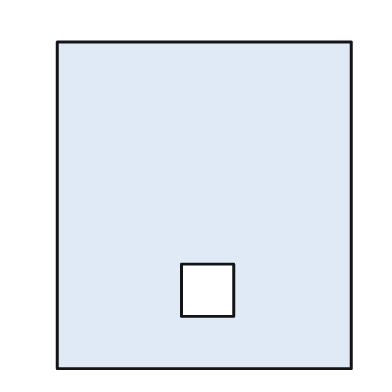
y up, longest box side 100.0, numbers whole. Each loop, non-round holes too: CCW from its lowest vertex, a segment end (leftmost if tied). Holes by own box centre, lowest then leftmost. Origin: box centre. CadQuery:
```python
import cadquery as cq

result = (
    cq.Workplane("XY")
    .moveTo(-45.0, -50.0)
    .lineTo(45.0, -50.0)
    .lineTo(45.0, 50.0)
    .lineTo(-45.0, 50.0)
    .close()
    .moveTo(-7.0, -34.0)
    .lineTo(9.0, -34.0)
    .lineTo(9.0, -18.0)
    .lineTo(-7.0, -18.0)
    .close()
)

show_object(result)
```